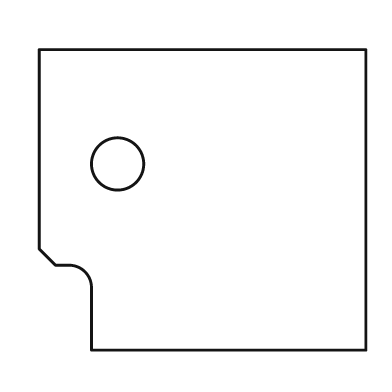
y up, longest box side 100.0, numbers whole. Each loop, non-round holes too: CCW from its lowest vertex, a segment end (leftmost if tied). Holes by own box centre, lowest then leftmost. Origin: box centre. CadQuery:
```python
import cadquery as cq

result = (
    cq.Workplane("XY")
    .moveTo(-34.0, -46.0)
    .lineTo(50.0, -46.0)
    .lineTo(50.0, 46.0)
    .lineTo(-50.0, 46.0)
    .lineTo(-50.0, -15.0)
    .lineTo(-45.0, -20.0)
    .lineTo(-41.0, -20.0)
    .threePointArc((-36.0, -22.0), (-34.0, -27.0))
    .close()
    .moveTo(-26.0, 11.0)
    .circle(8.0)
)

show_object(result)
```